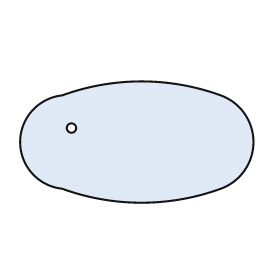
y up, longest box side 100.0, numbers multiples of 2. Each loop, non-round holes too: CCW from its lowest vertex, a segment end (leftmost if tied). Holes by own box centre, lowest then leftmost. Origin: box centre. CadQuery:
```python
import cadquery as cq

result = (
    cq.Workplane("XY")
    .moveTo(-32.0, -20.0)
    .threePointArc((2.0, -26.0), (36.0, -20.0))
    .threePointArc((50.0, 0.0), (36.0, 20.0))
    .threePointArc((2.0, 26.0), (-32.0, 20.0))
    .threePointArc((-50.0, 0.0), (-32.0, -20.0))
    .close()
    .moveTo(-28.0, 6.0)
    .circle(2.0)
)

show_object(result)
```